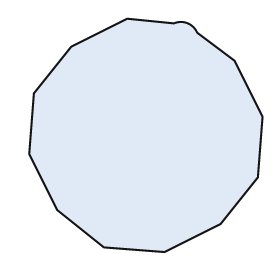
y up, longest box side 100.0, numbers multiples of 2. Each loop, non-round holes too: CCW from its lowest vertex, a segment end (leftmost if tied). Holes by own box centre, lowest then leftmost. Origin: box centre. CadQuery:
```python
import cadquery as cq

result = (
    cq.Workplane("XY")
    .moveTo(8.0, -50.0)
    .lineTo(32.0, -38.0)
    .lineTo(48.0, -18.0)
    .lineTo(50.0, 8.0)
    .lineTo(38.0, 32.0)
    .lineTo(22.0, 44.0)
    .threePointArc((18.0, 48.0), (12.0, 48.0))
    .lineTo(-8.0, 50.0)
    .lineTo(-32.0, 38.0)
    .lineTo(-48.0, 18.0)
    .lineTo(-50.0, -8.0)
    .lineTo(-38.0, -32.0)
    .lineTo(-18.0, -48.0)
    .close()
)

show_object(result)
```